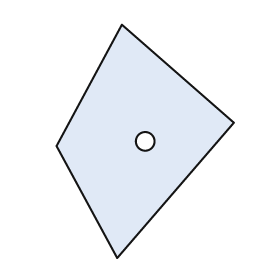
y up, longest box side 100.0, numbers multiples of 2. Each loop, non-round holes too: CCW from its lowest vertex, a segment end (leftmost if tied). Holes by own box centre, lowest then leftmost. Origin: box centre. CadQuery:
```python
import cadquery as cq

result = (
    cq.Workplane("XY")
    .moveTo(-12.0, -50.0)
    .lineTo(38.0, 8.0)
    .lineTo(-10.0, 50.0)
    .lineTo(-38.0, -2.0)
    .close()
    .moveTo(0.0, 0.0)
    .circle(4.0)
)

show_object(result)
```